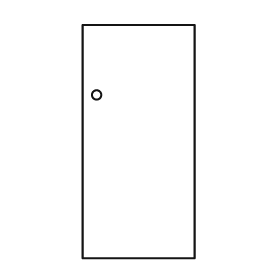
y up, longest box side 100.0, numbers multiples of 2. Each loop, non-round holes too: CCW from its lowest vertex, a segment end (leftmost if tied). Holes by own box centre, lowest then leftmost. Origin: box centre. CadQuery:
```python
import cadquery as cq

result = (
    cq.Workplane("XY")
    .moveTo(-24.0, -50.0)
    .lineTo(24.0, -50.0)
    .lineTo(24.0, 50.0)
    .lineTo(-24.0, 50.0)
    .close()
    .moveTo(-18.0, 20.0)
    .circle(2.0)
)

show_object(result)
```